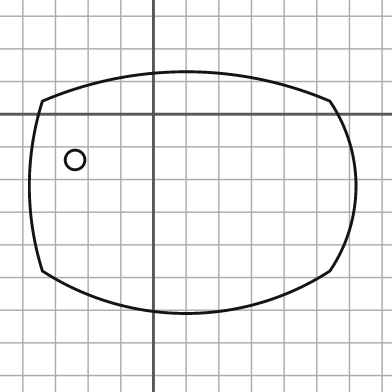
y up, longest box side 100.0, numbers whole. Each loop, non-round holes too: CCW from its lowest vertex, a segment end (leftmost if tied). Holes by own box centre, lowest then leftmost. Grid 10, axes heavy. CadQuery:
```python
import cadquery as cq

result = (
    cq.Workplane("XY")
    .moveTo(-34.0, -48.0)
    .threePointArc((10.0, -61.0), (54.0, -48.0))
    .threePointArc((62.0, -22.0), (54.0, 4.0))
    .threePointArc((10.0, 13.0), (-34.0, 4.0))
    .threePointArc((-38.0, -22.0), (-34.0, -48.0))
    .close()
    .moveTo(-24.0, -14.0)
    .circle(3.0)
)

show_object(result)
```